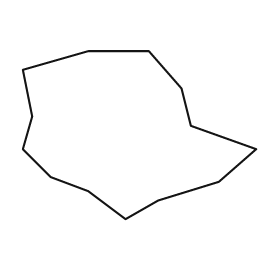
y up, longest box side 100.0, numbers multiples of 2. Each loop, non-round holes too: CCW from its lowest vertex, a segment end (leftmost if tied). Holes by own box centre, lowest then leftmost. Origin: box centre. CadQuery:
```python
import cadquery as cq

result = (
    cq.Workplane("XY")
    .moveTo(-6.0, -36.0)
    .lineTo(8.0, -28.0)
    .lineTo(34.0, -20.0)
    .lineTo(50.0, -6.0)
    .lineTo(22.0, 4.0)
    .lineTo(18.0, 20.0)
    .lineTo(4.0, 36.0)
    .lineTo(-22.0, 36.0)
    .lineTo(-50.0, 28.0)
    .lineTo(-46.0, 8.0)
    .lineTo(-50.0, -6.0)
    .lineTo(-38.0, -18.0)
    .lineTo(-22.0, -24.0)
    .close()
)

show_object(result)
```